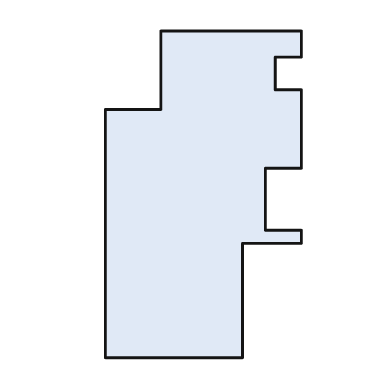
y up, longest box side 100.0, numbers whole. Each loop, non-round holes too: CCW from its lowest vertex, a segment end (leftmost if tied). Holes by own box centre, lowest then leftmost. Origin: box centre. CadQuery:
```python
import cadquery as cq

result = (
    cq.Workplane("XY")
    .moveTo(-30.0, -50.0)
    .lineTo(12.0, -50.0)
    .lineTo(12.0, -15.0)
    .lineTo(30.0, -15.0)
    .lineTo(30.0, -11.0)
    .lineTo(19.0, -11.0)
    .lineTo(19.0, 8.0)
    .lineTo(30.0, 8.0)
    .lineTo(30.0, 32.0)
    .lineTo(22.0, 32.0)
    .lineTo(22.0, 42.0)
    .lineTo(30.0, 42.0)
    .lineTo(30.0, 50.0)
    .lineTo(-13.0, 50.0)
    .lineTo(-13.0, 26.0)
    .lineTo(-30.0, 26.0)
    .close()
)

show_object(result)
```